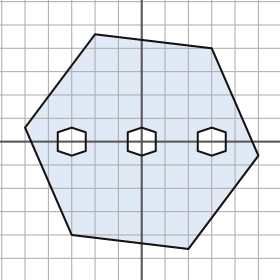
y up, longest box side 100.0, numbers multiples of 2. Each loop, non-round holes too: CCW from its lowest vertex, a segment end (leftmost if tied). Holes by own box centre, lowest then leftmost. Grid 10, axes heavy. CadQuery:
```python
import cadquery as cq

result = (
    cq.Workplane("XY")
    .moveTo(20.0, -46.0)
    .lineTo(50.0, -6.0)
    .lineTo(30.0, 40.0)
    .lineTo(-20.0, 46.0)
    .lineTo(-50.0, 6.0)
    .lineTo(-30.0, -40.0)
    .close()
    .moveTo(-30.0, -6.0)
    .lineTo(-24.0, -4.0)
    .lineTo(-24.0, 4.0)
    .lineTo(-30.0, 6.0)
    .lineTo(-36.0, 4.0)
    .lineTo(-36.0, -4.0)
    .close()
    .moveTo(0.0, -6.0)
    .lineTo(6.0, -4.0)
    .lineTo(6.0, 4.0)
    .lineTo(0.0, 6.0)
    .lineTo(-6.0, 4.0)
    .lineTo(-6.0, -4.0)
    .close()
    .moveTo(30.0, -6.0)
    .lineTo(36.0, -4.0)
    .lineTo(36.0, 4.0)
    .lineTo(30.0, 6.0)
    .lineTo(24.0, 4.0)
    .lineTo(24.0, -4.0)
    .close()
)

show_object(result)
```